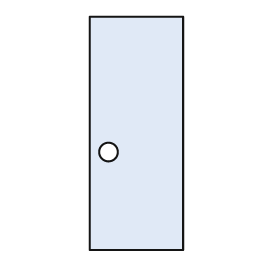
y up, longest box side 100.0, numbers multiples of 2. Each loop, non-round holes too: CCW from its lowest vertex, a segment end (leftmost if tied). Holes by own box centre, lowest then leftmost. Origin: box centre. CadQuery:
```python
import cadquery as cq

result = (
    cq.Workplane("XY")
    .moveTo(-20.0, -50.0)
    .lineTo(20.0, -50.0)
    .lineTo(20.0, 50.0)
    .lineTo(-20.0, 50.0)
    .close()
    .moveTo(-12.0, -8.0)
    .circle(4.0)
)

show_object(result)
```